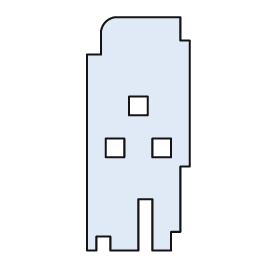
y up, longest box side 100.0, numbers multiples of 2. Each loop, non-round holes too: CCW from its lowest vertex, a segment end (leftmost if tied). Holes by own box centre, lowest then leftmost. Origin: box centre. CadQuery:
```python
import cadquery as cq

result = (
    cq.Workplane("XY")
    .moveTo(-22.0, -50.0)
    .lineTo(-18.0, -50.0)
    .lineTo(-18.0, -44.0)
    .lineTo(-12.0, -44.0)
    .lineTo(-12.0, -50.0)
    .lineTo(0.0, -50.0)
    .lineTo(0.0, -28.0)
    .lineTo(6.0, -28.0)
    .lineTo(6.0, -50.0)
    .lineTo(14.0, -50.0)
    .lineTo(14.0, -42.0)
    .lineTo(18.0, -42.0)
    .lineTo(18.0, -14.0)
    .lineTo(22.0, -14.0)
    .lineTo(22.0, 40.0)
    .lineTo(18.0, 40.0)
    .lineTo(18.0, 50.0)
    .lineTo(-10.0, 50.0)
    .threePointArc((-14.0, 48.0), (-16.0, 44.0))
    .lineTo(-16.0, 34.0)
    .lineTo(-22.0, 34.0)
    .close()
    .moveTo(-14.0, -10.0)
    .lineTo(-6.0, -10.0)
    .lineTo(-6.0, -2.0)
    .lineTo(-14.0, -2.0)
    .close()
    .moveTo(6.0, -10.0)
    .lineTo(14.0, -10.0)
    .lineTo(14.0, -2.0)
    .lineTo(6.0, -2.0)
    .close()
    .moveTo(-4.0, 8.0)
    .lineTo(4.0, 8.0)
    .lineTo(4.0, 16.0)
    .lineTo(-4.0, 16.0)
    .close()
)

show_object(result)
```